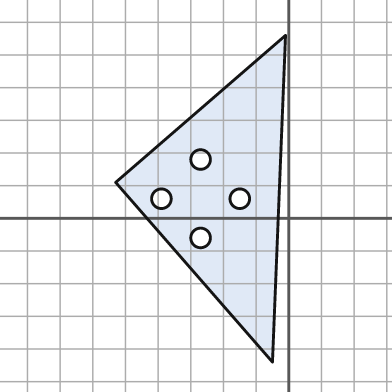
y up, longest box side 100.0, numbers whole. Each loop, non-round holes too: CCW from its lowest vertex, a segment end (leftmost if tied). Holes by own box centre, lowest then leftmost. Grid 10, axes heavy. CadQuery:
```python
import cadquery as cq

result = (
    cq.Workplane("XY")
    .moveTo(-5.0, -44.0)
    .lineTo(-1.0, 56.0)
    .lineTo(-53.0, 11.0)
    .close()
    .moveTo(-27.0, -6.0)
    .circle(3.0)
    .moveTo(-39.0, 6.0)
    .circle(3.0)
    .moveTo(-15.0, 6.0)
    .circle(3.0)
    .moveTo(-27.0, 18.0)
    .circle(3.0)
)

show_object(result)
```